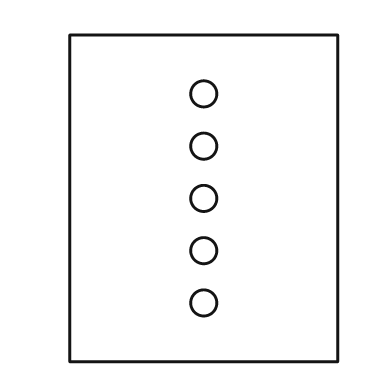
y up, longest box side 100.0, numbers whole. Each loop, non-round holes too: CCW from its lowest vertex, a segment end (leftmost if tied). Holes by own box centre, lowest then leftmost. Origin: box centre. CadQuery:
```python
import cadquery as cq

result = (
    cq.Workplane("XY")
    .moveTo(-41.0, -50.0)
    .lineTo(41.0, -50.0)
    .lineTo(41.0, 50.0)
    .lineTo(-41.0, 50.0)
    .close()
    .moveTo(0.0, -32.0)
    .circle(4.0)
    .moveTo(0.0, -16.0)
    .circle(4.0)
    .moveTo(0.0, 0.0)
    .circle(4.0)
    .moveTo(0.0, 16.0)
    .circle(4.0)
    .moveTo(0.0, 32.0)
    .circle(4.0)
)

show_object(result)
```